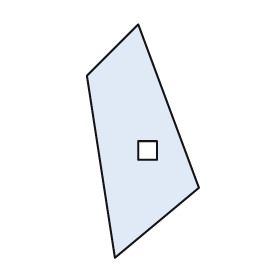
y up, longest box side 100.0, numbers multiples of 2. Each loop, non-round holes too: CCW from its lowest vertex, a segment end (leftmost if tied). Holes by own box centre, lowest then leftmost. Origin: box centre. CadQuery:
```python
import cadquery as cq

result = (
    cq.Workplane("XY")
    .moveTo(-12.0, -50.0)
    .lineTo(24.0, -20.0)
    .lineTo(-2.0, 50.0)
    .lineTo(-24.0, 28.0)
    .close()
    .moveTo(-2.0, -8.0)
    .lineTo(6.0, -8.0)
    .lineTo(6.0, 0.0)
    .lineTo(-2.0, 0.0)
    .close()
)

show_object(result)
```